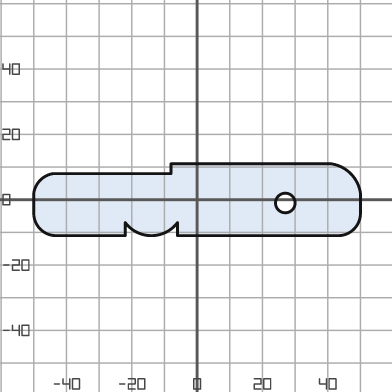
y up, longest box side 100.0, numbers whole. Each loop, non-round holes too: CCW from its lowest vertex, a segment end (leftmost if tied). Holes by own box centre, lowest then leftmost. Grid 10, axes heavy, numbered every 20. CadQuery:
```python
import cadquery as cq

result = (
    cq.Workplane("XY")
    .moveTo(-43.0, -11.0)
    .lineTo(-22.0, -11.0)
    .lineTo(-22.0, -7.0)
    .threePointArc((-14.0, -11.0), (-6.0, -7.0))
    .lineTo(-6.0, -11.0)
    .lineTo(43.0, -11.0)
    .threePointArc((48.0, -9.0), (50.0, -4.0))
    .lineTo(50.0, 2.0)
    .threePointArc((47.0, 8.0), (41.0, 11.0))
    .lineTo(-8.0, 11.0)
    .lineTo(-8.0, 8.0)
    .lineTo(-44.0, 8.0)
    .threePointArc((-48.0, 6.0), (-50.0, 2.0))
    .lineTo(-50.0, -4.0)
    .threePointArc((-48.0, -9.0), (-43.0, -11.0))
    .close()
    .moveTo(27.0, -1.0)
    .circle(3.0)
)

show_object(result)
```